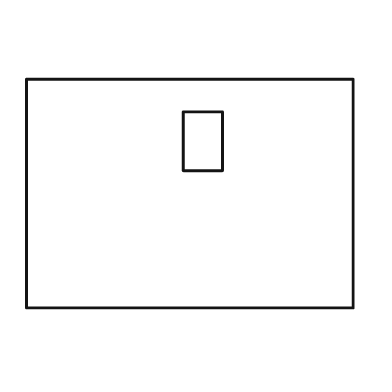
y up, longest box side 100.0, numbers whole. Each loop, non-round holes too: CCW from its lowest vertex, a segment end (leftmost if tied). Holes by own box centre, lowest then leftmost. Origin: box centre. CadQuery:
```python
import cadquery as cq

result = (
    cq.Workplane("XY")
    .moveTo(-50.0, -35.0)
    .lineTo(50.0, -35.0)
    .lineTo(50.0, 35.0)
    .lineTo(-50.0, 35.0)
    .close()
    .moveTo(-2.0, 7.0)
    .lineTo(10.0, 7.0)
    .lineTo(10.0, 25.0)
    .lineTo(-2.0, 25.0)
    .close()
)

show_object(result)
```